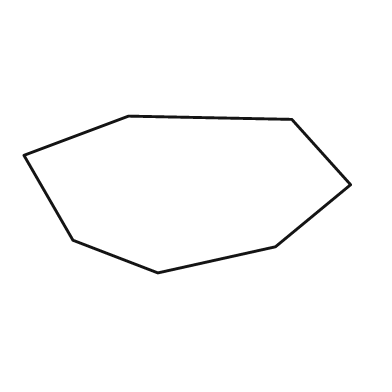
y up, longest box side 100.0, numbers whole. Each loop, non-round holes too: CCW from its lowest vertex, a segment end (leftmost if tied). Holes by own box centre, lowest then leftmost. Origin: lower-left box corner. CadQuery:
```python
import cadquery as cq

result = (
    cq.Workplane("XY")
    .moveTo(41.0, 0.0)
    .lineTo(77.0, 8.0)
    .lineTo(100.0, 27.0)
    .lineTo(82.0, 47.0)
    .lineTo(32.0, 48.0)
    .lineTo(0.0, 36.0)
    .lineTo(15.0, 10.0)
    .close()
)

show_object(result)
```